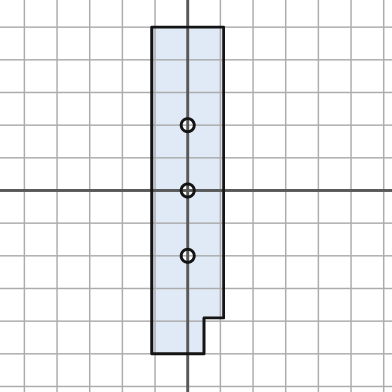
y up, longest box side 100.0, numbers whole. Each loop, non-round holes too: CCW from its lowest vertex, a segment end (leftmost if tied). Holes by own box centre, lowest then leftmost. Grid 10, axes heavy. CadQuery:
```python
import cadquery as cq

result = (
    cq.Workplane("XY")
    .moveTo(-11.0, -50.0)
    .lineTo(5.0, -50.0)
    .lineTo(5.0, -39.0)
    .lineTo(11.0, -39.0)
    .lineTo(11.0, 50.0)
    .lineTo(-11.0, 50.0)
    .close()
    .moveTo(0.0, -20.0)
    .circle(2.0)
    .moveTo(0.0, 0.0)
    .circle(2.0)
    .moveTo(0.0, 20.0)
    .circle(2.0)
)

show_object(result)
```